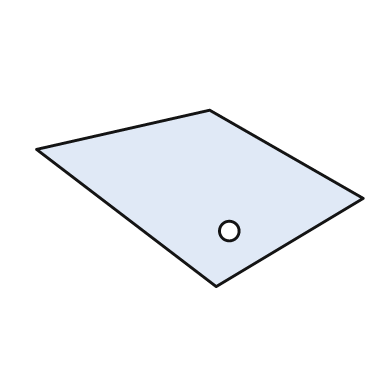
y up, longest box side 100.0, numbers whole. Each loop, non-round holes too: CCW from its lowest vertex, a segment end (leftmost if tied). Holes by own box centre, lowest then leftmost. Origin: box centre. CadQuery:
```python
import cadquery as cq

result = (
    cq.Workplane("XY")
    .moveTo(5.0, -27.0)
    .lineTo(50.0, 0.0)
    .lineTo(3.0, 27.0)
    .lineTo(-50.0, 15.0)
    .close()
    .moveTo(9.0, -10.0)
    .circle(3.0)
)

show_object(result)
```